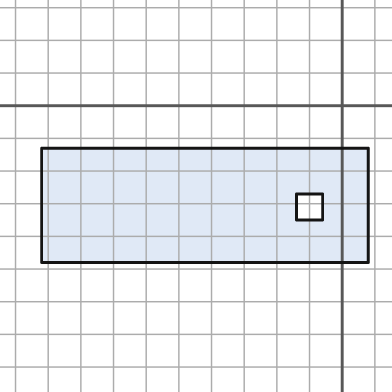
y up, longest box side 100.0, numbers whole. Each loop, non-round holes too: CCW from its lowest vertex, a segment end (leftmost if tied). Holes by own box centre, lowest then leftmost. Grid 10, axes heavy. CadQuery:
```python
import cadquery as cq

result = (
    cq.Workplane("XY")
    .moveTo(-92.0, -48.0)
    .lineTo(8.0, -48.0)
    .lineTo(8.0, -13.0)
    .lineTo(-92.0, -13.0)
    .close()
    .moveTo(-14.0, -35.0)
    .lineTo(-6.0, -35.0)
    .lineTo(-6.0, -27.0)
    .lineTo(-14.0, -27.0)
    .close()
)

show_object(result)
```